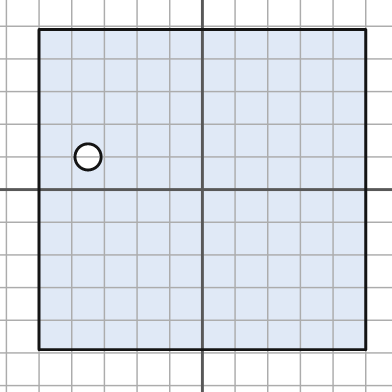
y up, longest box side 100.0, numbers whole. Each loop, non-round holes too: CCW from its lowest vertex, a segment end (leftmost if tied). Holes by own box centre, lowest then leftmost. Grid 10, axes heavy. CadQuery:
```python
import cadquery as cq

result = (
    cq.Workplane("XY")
    .moveTo(-50.0, -49.0)
    .lineTo(50.0, -49.0)
    .lineTo(50.0, 49.0)
    .lineTo(-50.0, 49.0)
    .close()
    .moveTo(-35.0, 10.0)
    .circle(4.0)
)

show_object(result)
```